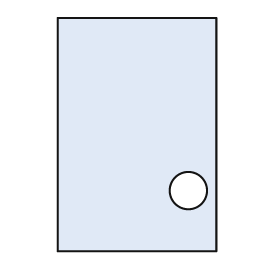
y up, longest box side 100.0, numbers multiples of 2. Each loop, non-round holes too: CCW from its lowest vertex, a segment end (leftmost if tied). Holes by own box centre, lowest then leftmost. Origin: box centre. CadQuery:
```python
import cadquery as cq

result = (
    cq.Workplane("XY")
    .moveTo(-34.0, -50.0)
    .lineTo(34.0, -50.0)
    .lineTo(34.0, 50.0)
    .lineTo(-34.0, 50.0)
    .close()
    .moveTo(22.0, -24.0)
    .circle(8.0)
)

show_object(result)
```